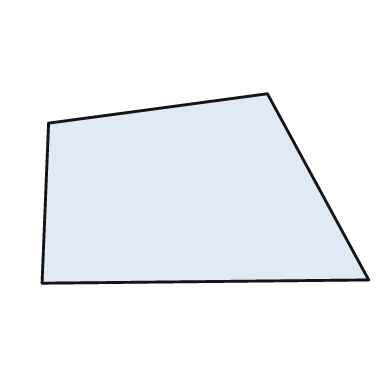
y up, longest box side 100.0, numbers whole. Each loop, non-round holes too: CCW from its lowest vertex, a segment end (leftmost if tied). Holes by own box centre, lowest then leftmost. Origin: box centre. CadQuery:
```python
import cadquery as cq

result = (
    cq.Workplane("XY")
    .moveTo(-50.0, -29.0)
    .lineTo(50.0, -28.0)
    .lineTo(19.0, 29.0)
    .lineTo(-48.0, 20.0)
    .close()
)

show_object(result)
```